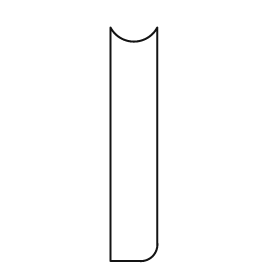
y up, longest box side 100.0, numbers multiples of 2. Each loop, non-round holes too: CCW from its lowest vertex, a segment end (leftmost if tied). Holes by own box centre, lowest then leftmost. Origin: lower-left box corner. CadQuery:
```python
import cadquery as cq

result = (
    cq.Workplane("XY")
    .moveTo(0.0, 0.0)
    .lineTo(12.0, 0.0)
    .threePointArc((18.0, 2.0), (20.0, 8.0))
    .lineTo(20.0, 100.0)
    .threePointArc((10.0, 94.0), (0.0, 100.0))
    .close()
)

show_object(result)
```